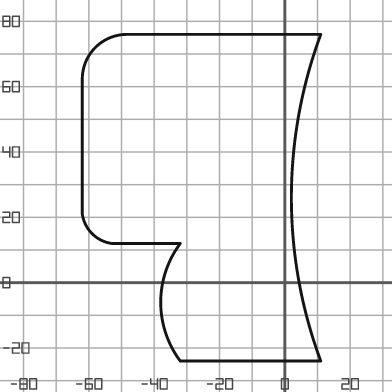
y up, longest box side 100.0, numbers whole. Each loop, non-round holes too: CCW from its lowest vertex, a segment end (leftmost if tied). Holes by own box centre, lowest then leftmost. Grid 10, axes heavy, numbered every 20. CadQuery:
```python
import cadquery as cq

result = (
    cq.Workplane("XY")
    .moveTo(-32.0, -24.0)
    .lineTo(11.0, -24.0)
    .threePointArc((2.0, 26.0), (11.0, 76.0))
    .lineTo(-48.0, 76.0)
    .threePointArc((-58.0, 72.0), (-62.0, 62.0))
    .lineTo(-62.0, 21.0)
    .threePointArc((-59.0, 15.0), (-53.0, 12.0))
    .lineTo(-32.0, 12.0)
    .threePointArc((-38.0, -6.0), (-32.0, -24.0))
    .close()
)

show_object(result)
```